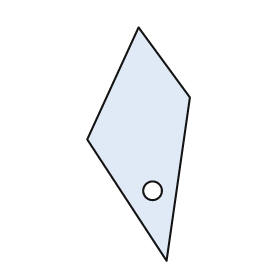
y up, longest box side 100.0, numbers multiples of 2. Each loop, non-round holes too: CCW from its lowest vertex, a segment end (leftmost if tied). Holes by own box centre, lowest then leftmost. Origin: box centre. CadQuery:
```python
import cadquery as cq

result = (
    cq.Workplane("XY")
    .moveTo(12.0, -50.0)
    .lineTo(22.0, 20.0)
    .lineTo(0.0, 50.0)
    .lineTo(-22.0, 2.0)
    .close()
    .moveTo(6.0, -20.0)
    .circle(4.0)
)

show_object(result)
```